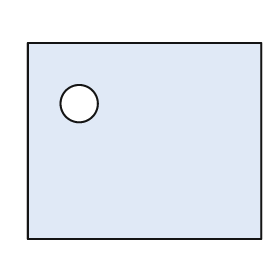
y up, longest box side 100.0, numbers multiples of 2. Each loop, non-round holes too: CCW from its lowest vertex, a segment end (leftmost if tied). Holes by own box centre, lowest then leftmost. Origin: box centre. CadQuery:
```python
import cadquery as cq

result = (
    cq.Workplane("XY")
    .moveTo(-50.0, -42.0)
    .lineTo(50.0, -42.0)
    .lineTo(50.0, 42.0)
    .lineTo(-50.0, 42.0)
    .close()
    .moveTo(-28.0, 16.0)
    .circle(8.0)
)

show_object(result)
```